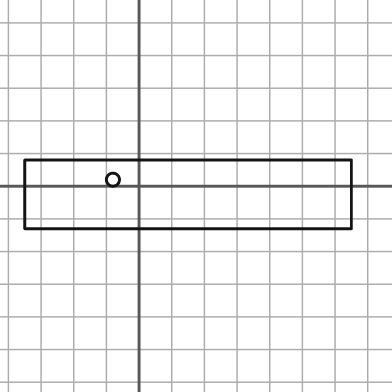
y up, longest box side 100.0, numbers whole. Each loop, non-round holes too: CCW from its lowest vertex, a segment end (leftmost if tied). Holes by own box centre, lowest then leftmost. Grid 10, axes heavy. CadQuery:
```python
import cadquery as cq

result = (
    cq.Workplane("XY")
    .moveTo(-35.0, -13.0)
    .lineTo(65.0, -13.0)
    .lineTo(65.0, 8.0)
    .lineTo(-35.0, 8.0)
    .close()
    .moveTo(-8.0, 2.0)
    .circle(2.0)
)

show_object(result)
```